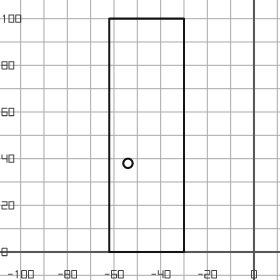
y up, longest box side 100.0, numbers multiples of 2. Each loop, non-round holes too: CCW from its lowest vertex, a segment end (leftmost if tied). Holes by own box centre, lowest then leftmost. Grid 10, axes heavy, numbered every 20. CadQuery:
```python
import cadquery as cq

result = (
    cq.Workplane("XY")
    .moveTo(-62.0, 0.0)
    .lineTo(-30.0, 0.0)
    .lineTo(-30.0, 100.0)
    .lineTo(-62.0, 100.0)
    .close()
    .moveTo(-54.0, 38.0)
    .circle(2.0)
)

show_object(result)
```